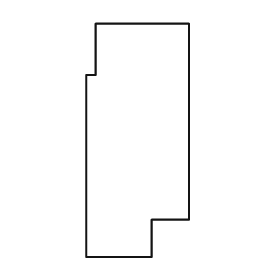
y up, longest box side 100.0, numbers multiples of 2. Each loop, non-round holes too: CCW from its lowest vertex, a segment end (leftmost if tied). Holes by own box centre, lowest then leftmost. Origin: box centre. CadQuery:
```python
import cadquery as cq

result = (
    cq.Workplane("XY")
    .moveTo(-22.0, -50.0)
    .lineTo(6.0, -50.0)
    .lineTo(6.0, -34.0)
    .lineTo(22.0, -34.0)
    .lineTo(22.0, 50.0)
    .lineTo(-18.0, 50.0)
    .lineTo(-18.0, 28.0)
    .lineTo(-22.0, 28.0)
    .close()
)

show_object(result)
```